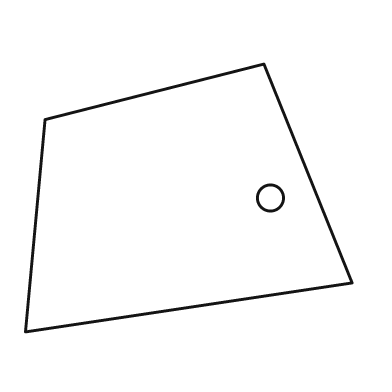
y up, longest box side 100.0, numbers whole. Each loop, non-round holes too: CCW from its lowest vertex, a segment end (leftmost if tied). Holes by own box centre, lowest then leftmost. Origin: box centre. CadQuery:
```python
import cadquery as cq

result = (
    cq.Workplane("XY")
    .moveTo(-50.0, -41.0)
    .lineTo(50.0, -26.0)
    .lineTo(23.0, 41.0)
    .lineTo(-44.0, 24.0)
    .close()
    .moveTo(25.0, 0.0)
    .circle(4.0)
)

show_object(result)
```